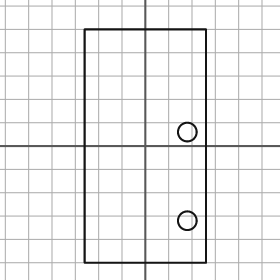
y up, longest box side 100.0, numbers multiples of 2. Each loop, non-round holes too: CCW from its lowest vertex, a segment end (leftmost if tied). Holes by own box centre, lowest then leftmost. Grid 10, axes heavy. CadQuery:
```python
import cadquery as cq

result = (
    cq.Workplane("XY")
    .moveTo(-26.0, -50.0)
    .lineTo(26.0, -50.0)
    .lineTo(26.0, 50.0)
    .lineTo(-26.0, 50.0)
    .close()
    .moveTo(18.0, -32.0)
    .circle(4.0)
    .moveTo(18.0, 6.0)
    .circle(4.0)
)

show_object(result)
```